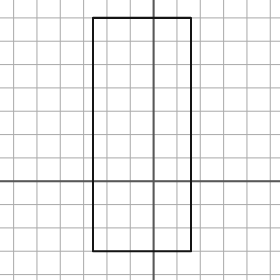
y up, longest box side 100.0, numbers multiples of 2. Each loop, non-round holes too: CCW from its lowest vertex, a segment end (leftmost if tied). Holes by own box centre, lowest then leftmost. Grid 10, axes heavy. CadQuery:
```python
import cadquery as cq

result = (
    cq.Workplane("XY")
    .moveTo(-26.0, -30.0)
    .lineTo(16.0, -30.0)
    .lineTo(16.0, 70.0)
    .lineTo(-26.0, 70.0)
    .close()
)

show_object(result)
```